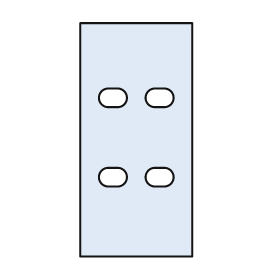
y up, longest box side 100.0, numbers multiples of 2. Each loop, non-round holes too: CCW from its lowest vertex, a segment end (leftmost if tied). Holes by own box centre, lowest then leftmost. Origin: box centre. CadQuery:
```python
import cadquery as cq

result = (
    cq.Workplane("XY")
    .moveTo(-24.0, -50.0)
    .lineTo(24.0, -50.0)
    .lineTo(24.0, 50.0)
    .lineTo(-24.0, 50.0)
    .close()
    .moveTo(-12.0, -20.0)
    .lineTo(-8.0, -20.0)
    .threePointArc((-4.0, -16.0), (-8.0, -12.0))
    .lineTo(-12.0, -12.0)
    .threePointArc((-16.0, -16.0), (-12.0, -20.0))
    .close()
    .moveTo(8.0, -20.0)
    .lineTo(12.0, -20.0)
    .threePointArc((16.0, -16.0), (12.0, -12.0))
    .lineTo(8.0, -12.0)
    .threePointArc((4.0, -16.0), (8.0, -20.0))
    .close()
    .moveTo(-12.0, 14.0)
    .lineTo(-8.0, 14.0)
    .threePointArc((-4.0, 18.0), (-8.0, 22.0))
    .lineTo(-12.0, 22.0)
    .threePointArc((-16.0, 18.0), (-12.0, 14.0))
    .close()
    .moveTo(8.0, 14.0)
    .lineTo(12.0, 14.0)
    .threePointArc((16.0, 18.0), (12.0, 22.0))
    .lineTo(8.0, 22.0)
    .threePointArc((4.0, 18.0), (8.0, 14.0))
    .close()
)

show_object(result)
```